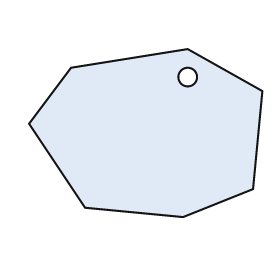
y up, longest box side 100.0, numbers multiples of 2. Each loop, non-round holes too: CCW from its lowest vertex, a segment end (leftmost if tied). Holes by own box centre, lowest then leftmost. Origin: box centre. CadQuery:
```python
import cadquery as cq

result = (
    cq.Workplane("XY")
    .moveTo(16.0, -36.0)
    .lineTo(46.0, -24.0)
    .lineTo(50.0, 18.0)
    .lineTo(18.0, 36.0)
    .lineTo(-32.0, 28.0)
    .lineTo(-50.0, 4.0)
    .lineTo(-26.0, -32.0)
    .close()
    .moveTo(18.0, 24.0)
    .circle(4.0)
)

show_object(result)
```